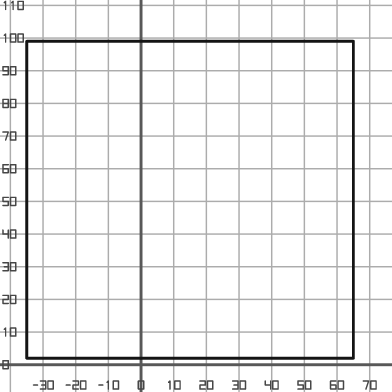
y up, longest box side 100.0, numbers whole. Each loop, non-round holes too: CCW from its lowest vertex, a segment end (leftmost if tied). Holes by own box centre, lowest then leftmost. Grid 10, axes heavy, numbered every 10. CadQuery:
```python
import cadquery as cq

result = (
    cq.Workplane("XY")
    .moveTo(-35.0, 2.0)
    .lineTo(65.0, 2.0)
    .lineTo(65.0, 99.0)
    .lineTo(-35.0, 99.0)
    .close()
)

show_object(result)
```